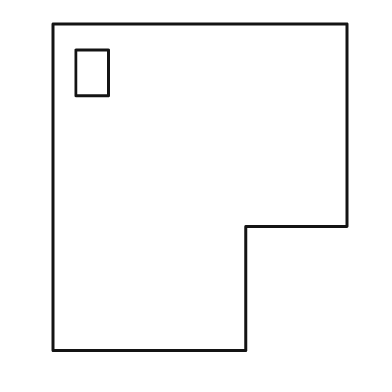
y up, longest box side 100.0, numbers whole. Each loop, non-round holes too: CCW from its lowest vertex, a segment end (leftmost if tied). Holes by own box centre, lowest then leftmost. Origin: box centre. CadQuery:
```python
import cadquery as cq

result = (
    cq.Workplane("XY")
    .moveTo(-45.0, -50.0)
    .lineTo(14.0, -50.0)
    .lineTo(14.0, -12.0)
    .lineTo(45.0, -12.0)
    .lineTo(45.0, 50.0)
    .lineTo(-45.0, 50.0)
    .close()
    .moveTo(-38.0, 28.0)
    .lineTo(-28.0, 28.0)
    .lineTo(-28.0, 42.0)
    .lineTo(-38.0, 42.0)
    .close()
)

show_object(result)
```